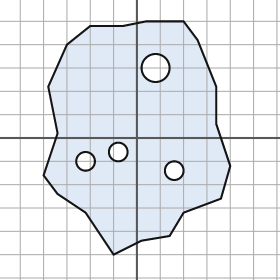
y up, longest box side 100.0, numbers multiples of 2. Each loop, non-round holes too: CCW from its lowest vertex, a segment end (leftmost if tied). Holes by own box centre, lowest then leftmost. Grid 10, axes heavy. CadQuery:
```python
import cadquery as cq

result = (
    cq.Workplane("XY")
    .moveTo(-10.0, -50.0)
    .lineTo(2.0, -44.0)
    .lineTo(14.0, -42.0)
    .lineTo(20.0, -32.0)
    .lineTo(36.0, -26.0)
    .lineTo(40.0, -12.0)
    .lineTo(34.0, 6.0)
    .lineTo(34.0, 22.0)
    .lineTo(26.0, 42.0)
    .lineTo(20.0, 50.0)
    .lineTo(4.0, 50.0)
    .lineTo(-6.0, 48.0)
    .lineTo(-20.0, 48.0)
    .lineTo(-30.0, 40.0)
    .lineTo(-38.0, 22.0)
    .lineTo(-34.0, 2.0)
    .lineTo(-40.0, -16.0)
    .lineTo(-34.0, -24.0)
    .lineTo(-22.0, -32.0)
    .close()
    .moveTo(16.0, -14.0)
    .circle(4.0)
    .moveTo(-22.0, -10.0)
    .circle(4.0)
    .moveTo(-8.0, -6.0)
    .circle(4.0)
    .moveTo(8.0, 30.0)
    .circle(6.0)
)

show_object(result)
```